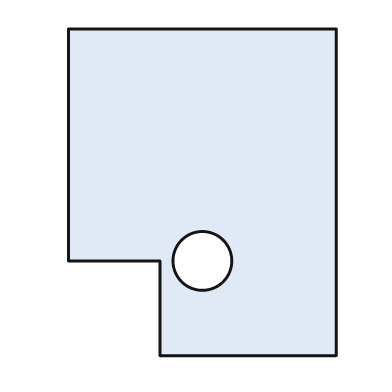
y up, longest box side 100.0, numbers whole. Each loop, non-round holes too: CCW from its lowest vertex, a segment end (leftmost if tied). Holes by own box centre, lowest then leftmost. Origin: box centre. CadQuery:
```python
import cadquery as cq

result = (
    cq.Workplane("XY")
    .moveTo(-13.0, -50.0)
    .lineTo(41.0, -50.0)
    .lineTo(41.0, 50.0)
    .lineTo(-41.0, 50.0)
    .lineTo(-41.0, -21.0)
    .lineTo(-13.0, -21.0)
    .close()
    .moveTo(0.0, -21.0)
    .circle(9.0)
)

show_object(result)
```